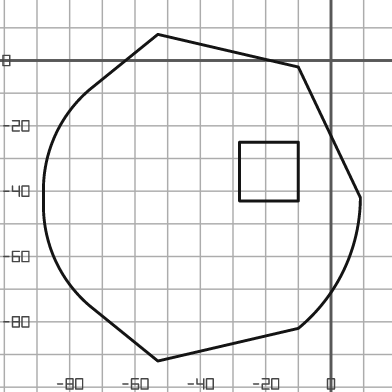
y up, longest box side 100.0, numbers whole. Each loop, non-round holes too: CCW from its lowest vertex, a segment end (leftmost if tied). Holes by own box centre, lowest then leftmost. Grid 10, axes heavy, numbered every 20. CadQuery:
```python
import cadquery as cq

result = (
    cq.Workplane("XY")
    .moveTo(-53.0, -92.0)
    .lineTo(-10.0, -82.0)
    .threePointArc((4.0, -64.0), (9.0, -42.0))
    .lineTo(-10.0, -2.0)
    .lineTo(-53.0, 8.0)
    .lineTo(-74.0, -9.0)
    .threePointArc((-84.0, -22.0), (-88.0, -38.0))
    .lineTo(-88.0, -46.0)
    .threePointArc((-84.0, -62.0), (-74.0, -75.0))
    .close()
    .moveTo(-28.0, -43.0)
    .lineTo(-10.0, -43.0)
    .lineTo(-10.0, -25.0)
    .lineTo(-28.0, -25.0)
    .close()
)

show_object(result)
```